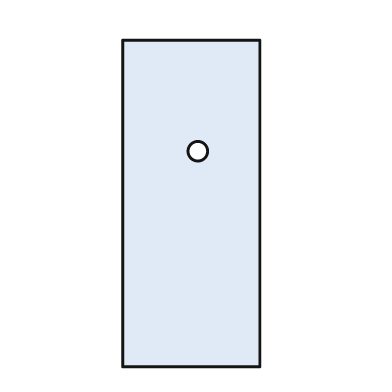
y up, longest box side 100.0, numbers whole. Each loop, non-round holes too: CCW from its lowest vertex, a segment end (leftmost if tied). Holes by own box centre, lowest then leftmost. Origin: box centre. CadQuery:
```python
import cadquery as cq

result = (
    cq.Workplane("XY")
    .moveTo(-21.0, -50.0)
    .lineTo(21.0, -50.0)
    .lineTo(21.0, 50.0)
    .lineTo(-21.0, 50.0)
    .close()
    .moveTo(2.0, 16.0)
    .circle(3.0)
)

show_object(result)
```